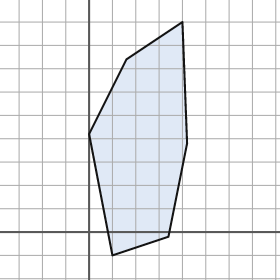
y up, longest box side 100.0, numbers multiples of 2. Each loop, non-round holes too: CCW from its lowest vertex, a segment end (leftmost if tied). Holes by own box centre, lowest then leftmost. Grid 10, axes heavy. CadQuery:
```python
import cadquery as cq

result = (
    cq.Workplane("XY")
    .moveTo(10.0, -10.0)
    .lineTo(34.0, -2.0)
    .lineTo(42.0, 38.0)
    .lineTo(40.0, 90.0)
    .lineTo(16.0, 74.0)
    .lineTo(0.0, 42.0)
    .close()
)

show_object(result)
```